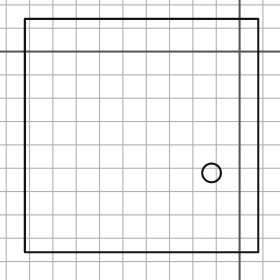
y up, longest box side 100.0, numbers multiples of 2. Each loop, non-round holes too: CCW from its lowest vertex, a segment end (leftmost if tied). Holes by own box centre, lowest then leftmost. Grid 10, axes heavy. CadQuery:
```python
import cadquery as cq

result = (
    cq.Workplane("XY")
    .moveTo(-92.0, -86.0)
    .lineTo(8.0, -86.0)
    .lineTo(8.0, 14.0)
    .lineTo(-92.0, 14.0)
    .close()
    .moveTo(-12.0, -52.0)
    .circle(4.0)
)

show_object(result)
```